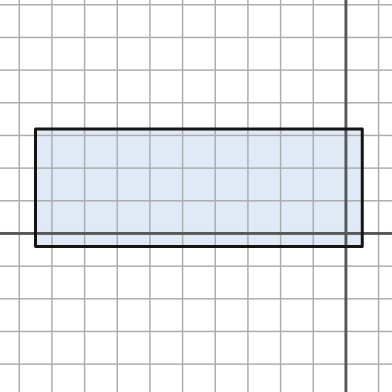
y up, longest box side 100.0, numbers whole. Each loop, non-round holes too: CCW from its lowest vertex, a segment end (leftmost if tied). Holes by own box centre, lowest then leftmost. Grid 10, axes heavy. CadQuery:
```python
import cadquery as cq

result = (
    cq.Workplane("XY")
    .moveTo(-95.0, -4.0)
    .lineTo(5.0, -4.0)
    .lineTo(5.0, 32.0)
    .lineTo(-95.0, 32.0)
    .close()
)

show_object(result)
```